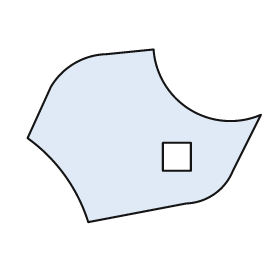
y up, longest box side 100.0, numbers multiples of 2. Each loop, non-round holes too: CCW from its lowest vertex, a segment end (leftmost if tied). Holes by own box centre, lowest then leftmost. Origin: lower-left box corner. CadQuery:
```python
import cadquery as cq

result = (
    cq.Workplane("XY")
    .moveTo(26.0, 0.0)
    .lineTo(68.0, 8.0)
    .threePointArc((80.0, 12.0), (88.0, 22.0))
    .lineTo(100.0, 46.0)
    .threePointArc((70.0, 48.0), (54.0, 74.0))
    .lineTo(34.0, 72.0)
    .threePointArc((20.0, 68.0), (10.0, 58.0))
    .lineTo(0.0, 36.0)
    .threePointArc((16.0, 20.0), (26.0, 0.0))
    .close()
    .moveTo(58.0, 22.0)
    .lineTo(70.0, 22.0)
    .lineTo(70.0, 34.0)
    .lineTo(58.0, 34.0)
    .close()
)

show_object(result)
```